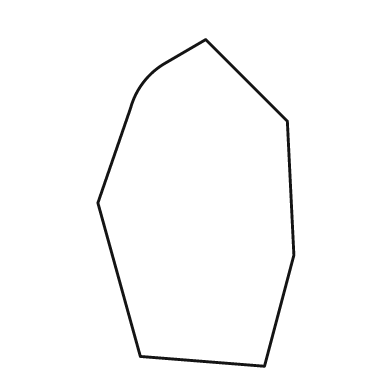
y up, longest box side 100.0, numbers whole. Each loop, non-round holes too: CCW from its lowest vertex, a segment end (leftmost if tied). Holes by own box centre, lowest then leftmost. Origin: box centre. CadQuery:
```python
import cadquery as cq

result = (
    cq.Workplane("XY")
    .moveTo(21.0, -50.0)
    .lineTo(30.0, -16.0)
    .lineTo(28.0, 25.0)
    .lineTo(3.0, 50.0)
    .lineTo(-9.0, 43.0)
    .threePointArc((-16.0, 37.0), (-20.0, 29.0))
    .lineTo(-30.0, 0.0)
    .lineTo(-17.0, -47.0)
    .close()
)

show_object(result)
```